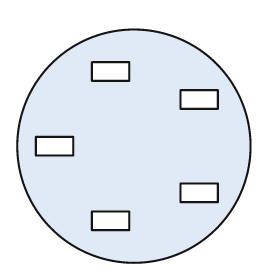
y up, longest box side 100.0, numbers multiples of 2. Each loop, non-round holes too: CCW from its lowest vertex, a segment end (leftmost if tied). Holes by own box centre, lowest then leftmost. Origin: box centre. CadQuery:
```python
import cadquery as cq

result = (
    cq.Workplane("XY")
    .moveTo(0.0, 0.0)
    .circle(50.0)
    .moveTo(-18.0, -36.0)
    .lineTo(-2.0, -36.0)
    .lineTo(-2.0, -28.0)
    .lineTo(-18.0, -28.0)
    .close()
    .moveTo(20.0, -24.0)
    .lineTo(36.0, -24.0)
    .lineTo(36.0, -16.0)
    .lineTo(20.0, -16.0)
    .close()
    .moveTo(-42.0, -4.0)
    .lineTo(-26.0, -4.0)
    .lineTo(-26.0, 4.0)
    .lineTo(-42.0, 4.0)
    .close()
    .moveTo(20.0, 16.0)
    .lineTo(36.0, 16.0)
    .lineTo(36.0, 24.0)
    .lineTo(20.0, 24.0)
    .close()
    .moveTo(-18.0, 28.0)
    .lineTo(-2.0, 28.0)
    .lineTo(-2.0, 36.0)
    .lineTo(-18.0, 36.0)
    .close()
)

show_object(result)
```